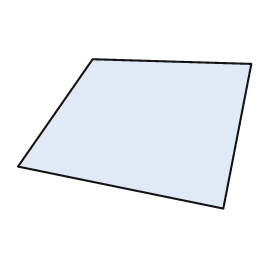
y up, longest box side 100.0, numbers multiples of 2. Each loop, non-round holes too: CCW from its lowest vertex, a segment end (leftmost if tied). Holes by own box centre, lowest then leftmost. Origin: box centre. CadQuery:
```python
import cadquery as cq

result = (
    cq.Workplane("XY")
    .moveTo(38.0, -32.0)
    .lineTo(50.0, 30.0)
    .lineTo(-18.0, 32.0)
    .lineTo(-50.0, -14.0)
    .close()
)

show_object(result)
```